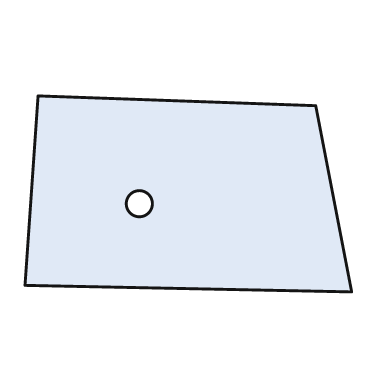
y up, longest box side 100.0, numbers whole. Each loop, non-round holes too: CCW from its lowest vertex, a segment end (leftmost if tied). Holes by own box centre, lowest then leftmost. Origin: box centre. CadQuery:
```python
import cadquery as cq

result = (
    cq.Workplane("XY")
    .moveTo(50.0, -30.0)
    .lineTo(39.0, 27.0)
    .lineTo(-46.0, 30.0)
    .lineTo(-50.0, -28.0)
    .close()
    .moveTo(-15.0, -3.0)
    .circle(4.0)
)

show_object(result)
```